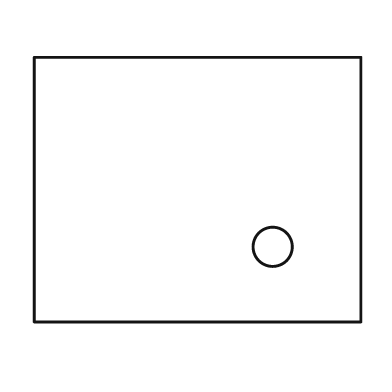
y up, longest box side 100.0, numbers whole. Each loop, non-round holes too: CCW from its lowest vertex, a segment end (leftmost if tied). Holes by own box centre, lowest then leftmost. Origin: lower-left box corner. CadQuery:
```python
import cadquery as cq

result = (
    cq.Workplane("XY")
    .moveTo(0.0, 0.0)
    .lineTo(100.0, 0.0)
    .lineTo(100.0, 81.0)
    .lineTo(0.0, 81.0)
    .close()
    .moveTo(73.0, 23.0)
    .circle(6.0)
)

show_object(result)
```